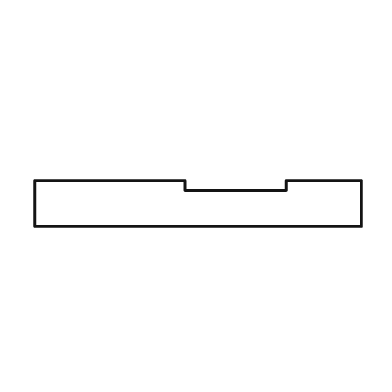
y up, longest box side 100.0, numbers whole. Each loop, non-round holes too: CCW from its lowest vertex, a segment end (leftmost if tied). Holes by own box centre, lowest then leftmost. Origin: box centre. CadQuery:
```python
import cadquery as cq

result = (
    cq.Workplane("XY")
    .moveTo(-50.0, -7.0)
    .lineTo(50.0, -7.0)
    .lineTo(50.0, 7.0)
    .lineTo(27.0, 7.0)
    .lineTo(27.0, 4.0)
    .lineTo(-4.0, 4.0)
    .lineTo(-4.0, 7.0)
    .lineTo(-50.0, 7.0)
    .close()
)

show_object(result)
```